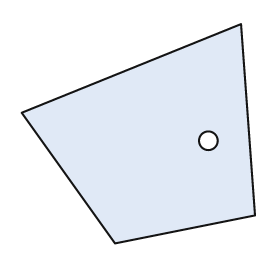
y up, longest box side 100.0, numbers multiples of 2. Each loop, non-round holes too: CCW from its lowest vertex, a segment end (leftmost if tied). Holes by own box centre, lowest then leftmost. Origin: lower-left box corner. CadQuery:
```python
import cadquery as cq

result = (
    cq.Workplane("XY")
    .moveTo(40.0, 0.0)
    .lineTo(100.0, 12.0)
    .lineTo(94.0, 94.0)
    .lineTo(0.0, 56.0)
    .close()
    .moveTo(80.0, 44.0)
    .circle(4.0)
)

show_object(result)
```